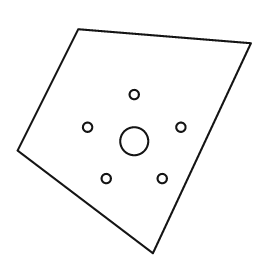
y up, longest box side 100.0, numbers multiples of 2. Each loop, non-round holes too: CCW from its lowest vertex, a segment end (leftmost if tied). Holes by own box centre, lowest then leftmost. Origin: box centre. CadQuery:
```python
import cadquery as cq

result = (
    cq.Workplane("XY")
    .moveTo(8.0, -48.0)
    .lineTo(50.0, 42.0)
    .lineTo(-24.0, 48.0)
    .lineTo(-50.0, -4.0)
    .close()
    .moveTo(-12.0, -16.0)
    .circle(2.0)
    .moveTo(12.0, -16.0)
    .circle(2.0)
    .moveTo(0.0, 0.0)
    .circle(6.0)
    .moveTo(-20.0, 6.0)
    .circle(2.0)
    .moveTo(20.0, 6.0)
    .circle(2.0)
    .moveTo(0.0, 20.0)
    .circle(2.0)
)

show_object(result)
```